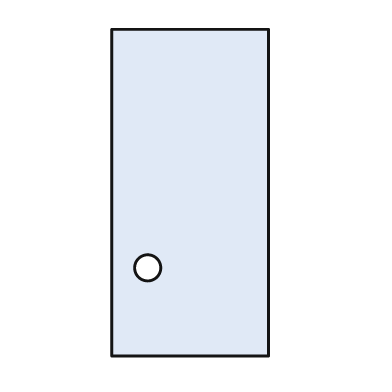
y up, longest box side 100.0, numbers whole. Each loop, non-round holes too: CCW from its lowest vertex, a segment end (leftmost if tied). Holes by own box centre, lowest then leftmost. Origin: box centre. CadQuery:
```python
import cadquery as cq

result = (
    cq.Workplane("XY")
    .moveTo(-24.0, -50.0)
    .lineTo(24.0, -50.0)
    .lineTo(24.0, 50.0)
    .lineTo(-24.0, 50.0)
    .close()
    .moveTo(-13.0, -23.0)
    .circle(4.0)
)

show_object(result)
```